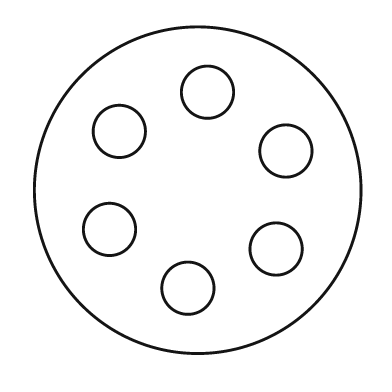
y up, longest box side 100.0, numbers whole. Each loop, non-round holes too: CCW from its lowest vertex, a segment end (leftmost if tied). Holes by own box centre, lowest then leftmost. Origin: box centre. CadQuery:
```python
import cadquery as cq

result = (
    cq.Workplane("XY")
    .moveTo(0.0, 0.0)
    .circle(50.0)
    .moveTo(-3.0, -30.0)
    .circle(8.0)
    .moveTo(24.0, -18.0)
    .circle(8.0)
    .moveTo(-27.0, -12.0)
    .circle(8.0)
    .moveTo(27.0, 12.0)
    .circle(8.0)
    .moveTo(-24.0, 18.0)
    .circle(8.0)
    .moveTo(3.0, 30.0)
    .circle(8.0)
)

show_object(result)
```